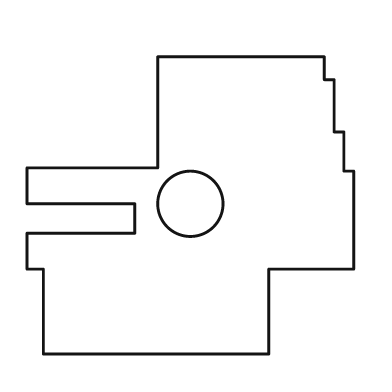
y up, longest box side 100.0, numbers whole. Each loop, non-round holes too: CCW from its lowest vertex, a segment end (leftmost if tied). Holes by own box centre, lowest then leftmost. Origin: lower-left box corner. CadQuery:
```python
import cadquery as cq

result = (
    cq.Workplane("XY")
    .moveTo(5.0, 0.0)
    .lineTo(74.0, 0.0)
    .lineTo(74.0, 26.0)
    .lineTo(100.0, 26.0)
    .lineTo(100.0, 56.0)
    .lineTo(97.0, 56.0)
    .lineTo(97.0, 68.0)
    .lineTo(94.0, 68.0)
    .lineTo(94.0, 84.0)
    .lineTo(91.0, 84.0)
    .lineTo(91.0, 91.0)
    .lineTo(40.0, 91.0)
    .lineTo(40.0, 57.0)
    .lineTo(0.0, 57.0)
    .lineTo(0.0, 46.0)
    .lineTo(33.0, 46.0)
    .lineTo(33.0, 37.0)
    .lineTo(0.0, 37.0)
    .lineTo(0.0, 26.0)
    .lineTo(5.0, 26.0)
    .close()
    .moveTo(50.0, 46.0)
    .circle(10.0)
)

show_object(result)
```